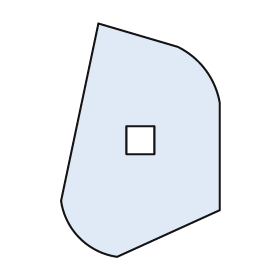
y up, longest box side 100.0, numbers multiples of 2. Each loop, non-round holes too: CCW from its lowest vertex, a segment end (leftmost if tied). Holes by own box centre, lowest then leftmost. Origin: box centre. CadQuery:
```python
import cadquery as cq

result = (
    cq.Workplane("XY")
    .moveTo(-10.0, -50.0)
    .lineTo(34.0, -30.0)
    .lineTo(34.0, 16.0)
    .threePointArc((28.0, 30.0), (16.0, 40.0))
    .lineTo(-18.0, 50.0)
    .lineTo(-34.0, -26.0)
    .threePointArc((-26.0, -42.0), (-10.0, -50.0))
    .close()
    .moveTo(-6.0, -6.0)
    .lineTo(6.0, -6.0)
    .lineTo(6.0, 6.0)
    .lineTo(-6.0, 6.0)
    .close()
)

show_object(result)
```